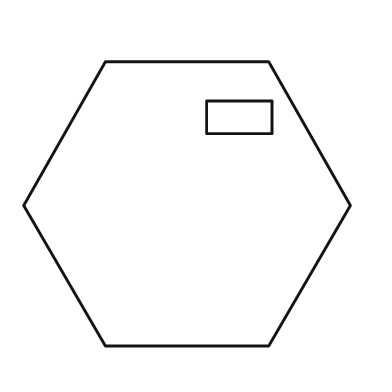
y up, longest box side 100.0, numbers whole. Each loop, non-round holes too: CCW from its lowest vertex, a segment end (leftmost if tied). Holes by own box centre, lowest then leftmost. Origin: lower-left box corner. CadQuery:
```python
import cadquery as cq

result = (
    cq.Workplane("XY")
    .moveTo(25.0, 0.0)
    .lineTo(75.0, 0.0)
    .lineTo(100.0, 43.0)
    .lineTo(75.0, 87.0)
    .lineTo(25.0, 87.0)
    .lineTo(0.0, 43.0)
    .close()
    .moveTo(56.0, 65.0)
    .lineTo(76.0, 65.0)
    .lineTo(76.0, 75.0)
    .lineTo(56.0, 75.0)
    .close()
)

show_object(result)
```